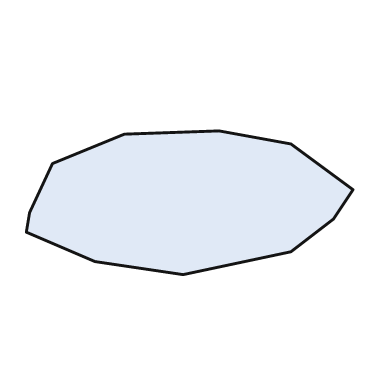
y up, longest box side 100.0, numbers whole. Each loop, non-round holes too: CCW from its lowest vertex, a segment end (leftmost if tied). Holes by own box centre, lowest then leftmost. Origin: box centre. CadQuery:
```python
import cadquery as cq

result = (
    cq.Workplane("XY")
    .moveTo(-2.0, -22.0)
    .lineTo(31.0, -15.0)
    .lineTo(44.0, -5.0)
    .lineTo(50.0, 4.0)
    .lineTo(31.0, 18.0)
    .lineTo(9.0, 22.0)
    .lineTo(-20.0, 21.0)
    .lineTo(-42.0, 12.0)
    .lineTo(-49.0, -3.0)
    .lineTo(-50.0, -9.0)
    .lineTo(-29.0, -18.0)
    .close()
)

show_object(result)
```